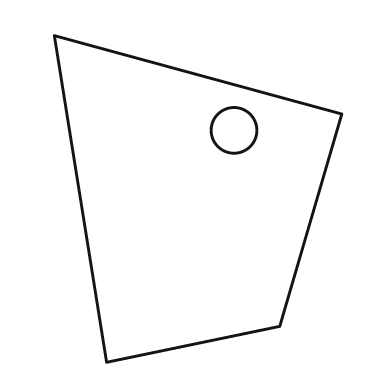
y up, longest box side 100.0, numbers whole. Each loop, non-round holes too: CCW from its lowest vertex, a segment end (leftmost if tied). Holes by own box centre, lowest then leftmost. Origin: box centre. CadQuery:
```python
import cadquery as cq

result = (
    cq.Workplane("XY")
    .moveTo(-28.0, -50.0)
    .lineTo(25.0, -39.0)
    .lineTo(44.0, 26.0)
    .lineTo(-44.0, 50.0)
    .close()
    .moveTo(11.0, 21.0)
    .circle(7.0)
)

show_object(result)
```